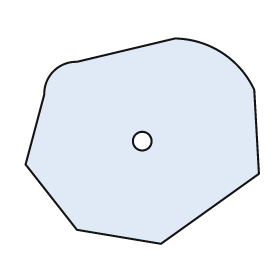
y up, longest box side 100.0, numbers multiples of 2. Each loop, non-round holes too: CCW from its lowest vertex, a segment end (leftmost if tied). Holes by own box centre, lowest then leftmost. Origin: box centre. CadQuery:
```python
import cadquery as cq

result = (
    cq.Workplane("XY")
    .moveTo(8.0, -44.0)
    .lineTo(50.0, -14.0)
    .lineTo(48.0, 22.0)
    .threePointArc((34.0, 38.0), (14.0, 44.0))
    .lineTo(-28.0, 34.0)
    .threePointArc((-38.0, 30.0), (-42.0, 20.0))
    .lineTo(-50.0, -10.0)
    .lineTo(-28.0, -38.0)
    .close()
    .moveTo(0.0, 0.0)
    .circle(4.0)
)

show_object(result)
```